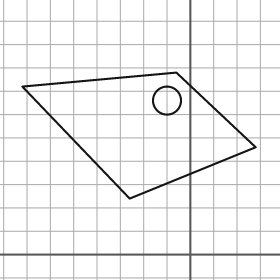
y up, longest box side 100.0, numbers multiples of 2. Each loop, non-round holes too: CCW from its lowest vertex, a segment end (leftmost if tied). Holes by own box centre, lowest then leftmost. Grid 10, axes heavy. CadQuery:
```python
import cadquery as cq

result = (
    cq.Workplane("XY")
    .moveTo(-26.0, 24.0)
    .lineTo(28.0, 46.0)
    .lineTo(-6.0, 78.0)
    .lineTo(-72.0, 72.0)
    .close()
    .moveTo(-10.0, 66.0)
    .circle(6.0)
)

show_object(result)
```